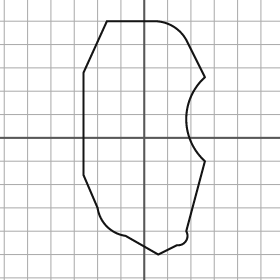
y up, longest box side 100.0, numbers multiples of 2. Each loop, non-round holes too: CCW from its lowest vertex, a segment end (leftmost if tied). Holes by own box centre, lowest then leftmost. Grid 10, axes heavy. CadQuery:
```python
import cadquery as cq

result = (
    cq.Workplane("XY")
    .moveTo(6.0, -50.0)
    .lineTo(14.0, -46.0)
    .threePointArc((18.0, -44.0), (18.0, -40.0))
    .lineTo(26.0, -10.0)
    .threePointArc((18.0, 8.0), (26.0, 26.0))
    .lineTo(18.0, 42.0)
    .threePointArc((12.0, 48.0), (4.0, 50.0))
    .lineTo(-16.0, 50.0)
    .lineTo(-26.0, 28.0)
    .lineTo(-26.0, -16.0)
    .lineTo(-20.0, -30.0)
    .threePointArc((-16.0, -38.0), (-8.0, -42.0))
    .close()
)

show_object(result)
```